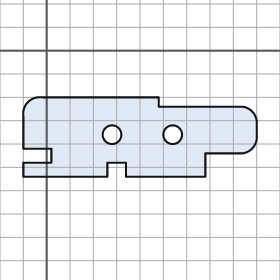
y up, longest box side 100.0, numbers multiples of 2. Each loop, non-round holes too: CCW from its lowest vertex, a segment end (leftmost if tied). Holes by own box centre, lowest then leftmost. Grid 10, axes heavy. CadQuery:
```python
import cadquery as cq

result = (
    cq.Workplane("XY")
    .moveTo(-10.0, -54.0)
    .lineTo(26.0, -54.0)
    .lineTo(26.0, -48.0)
    .lineTo(34.0, -48.0)
    .lineTo(34.0, -54.0)
    .lineTo(68.0, -54.0)
    .lineTo(68.0, -44.0)
    .lineTo(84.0, -44.0)
    .threePointArc((88.0, -42.0), (90.0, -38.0))
    .lineTo(90.0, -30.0)
    .threePointArc((88.0, -26.0), (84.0, -24.0))
    .lineTo(48.0, -24.0)
    .lineTo(48.0, -20.0)
    .lineTo(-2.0, -20.0)
    .threePointArc((-8.0, -22.0), (-10.0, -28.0))
    .lineTo(-10.0, -42.0)
    .lineTo(2.0, -42.0)
    .lineTo(2.0, -48.0)
    .lineTo(-10.0, -48.0)
    .close()
    .moveTo(28.0, -36.0)
    .circle(4.0)
    .moveTo(54.0, -36.0)
    .circle(4.0)
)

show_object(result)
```